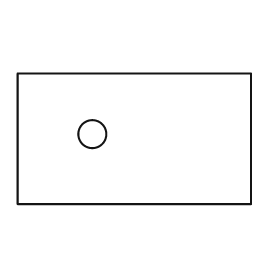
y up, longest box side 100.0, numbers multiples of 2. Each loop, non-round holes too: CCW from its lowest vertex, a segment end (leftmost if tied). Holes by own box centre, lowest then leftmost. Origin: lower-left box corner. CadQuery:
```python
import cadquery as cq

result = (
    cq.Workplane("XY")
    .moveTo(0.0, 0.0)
    .lineTo(100.0, 0.0)
    .lineTo(100.0, 56.0)
    .lineTo(0.0, 56.0)
    .close()
    .moveTo(32.0, 30.0)
    .circle(6.0)
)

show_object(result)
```